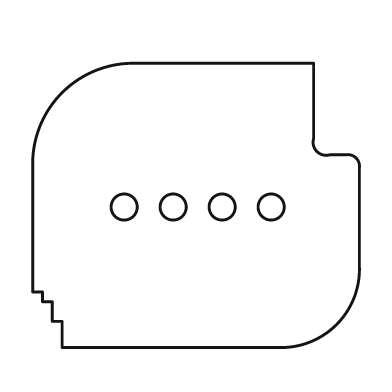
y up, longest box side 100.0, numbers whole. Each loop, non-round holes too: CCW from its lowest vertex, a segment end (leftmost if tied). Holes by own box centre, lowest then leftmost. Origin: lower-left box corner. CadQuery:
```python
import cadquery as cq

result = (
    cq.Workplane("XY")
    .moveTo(9.0, 0.0)
    .lineTo(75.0, 0.0)
    .threePointArc((93.0, 7.0), (100.0, 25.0))
    .lineTo(100.0, 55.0)
    .threePointArc((99.0, 58.0), (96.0, 59.0))
    .lineTo(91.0, 59.0)
    .threePointArc((87.0, 60.0), (86.0, 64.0))
    .lineTo(86.0, 87.0)
    .lineTo(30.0, 87.0)
    .threePointArc((9.0, 78.0), (0.0, 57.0))
    .lineTo(0.0, 17.0)
    .lineTo(3.0, 17.0)
    .lineTo(3.0, 14.0)
    .lineTo(6.0, 14.0)
    .lineTo(6.0, 8.0)
    .lineTo(9.0, 8.0)
    .close()
    .moveTo(28.0, 43.0)
    .circle(4.0)
    .moveTo(43.0, 43.0)
    .circle(4.0)
    .moveTo(58.0, 43.0)
    .circle(4.0)
    .moveTo(73.0, 43.0)
    .circle(4.0)
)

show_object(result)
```